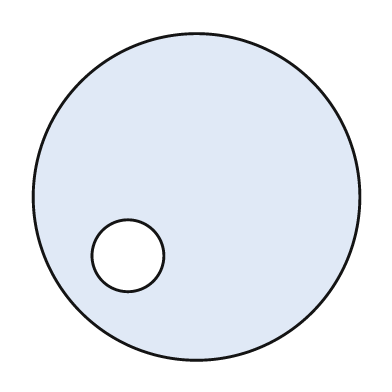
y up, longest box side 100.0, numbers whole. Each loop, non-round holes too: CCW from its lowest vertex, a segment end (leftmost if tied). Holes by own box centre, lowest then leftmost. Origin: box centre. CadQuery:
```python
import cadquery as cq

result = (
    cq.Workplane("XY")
    .moveTo(0.0, 0.0)
    .circle(50.0)
    .moveTo(-21.0, -18.0)
    .circle(11.0)
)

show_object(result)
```